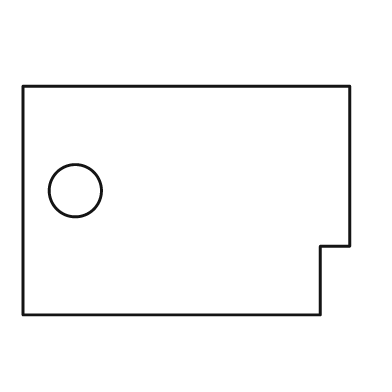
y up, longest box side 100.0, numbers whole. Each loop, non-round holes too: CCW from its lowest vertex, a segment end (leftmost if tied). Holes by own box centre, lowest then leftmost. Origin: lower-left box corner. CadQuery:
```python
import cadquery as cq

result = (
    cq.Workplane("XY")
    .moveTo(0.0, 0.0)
    .lineTo(91.0, 0.0)
    .lineTo(91.0, 21.0)
    .lineTo(100.0, 21.0)
    .lineTo(100.0, 70.0)
    .lineTo(0.0, 70.0)
    .close()
    .moveTo(16.0, 38.0)
    .circle(8.0)
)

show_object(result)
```